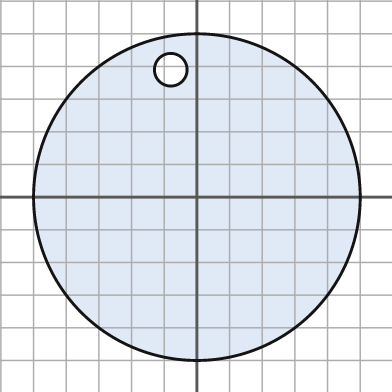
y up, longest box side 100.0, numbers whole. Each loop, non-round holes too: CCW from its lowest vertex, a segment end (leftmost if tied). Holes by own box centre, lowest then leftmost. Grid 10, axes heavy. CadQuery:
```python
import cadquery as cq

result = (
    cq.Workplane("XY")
    .moveTo(0.0, 0.0)
    .circle(50.0)
    .moveTo(-8.0, 39.0)
    .circle(5.0)
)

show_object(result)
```